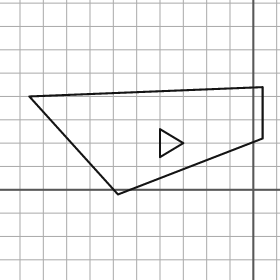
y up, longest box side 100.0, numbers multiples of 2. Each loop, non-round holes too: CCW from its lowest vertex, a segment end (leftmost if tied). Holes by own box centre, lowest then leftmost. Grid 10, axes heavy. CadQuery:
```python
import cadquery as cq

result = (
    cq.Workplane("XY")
    .moveTo(-58.0, -2.0)
    .lineTo(4.0, 22.0)
    .lineTo(4.0, 44.0)
    .lineTo(-96.0, 40.0)
    .close()
    .moveTo(-40.0, 14.0)
    .lineTo(-30.0, 20.0)
    .lineTo(-40.0, 26.0)
    .close()
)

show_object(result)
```